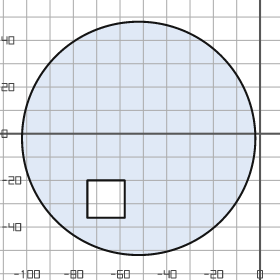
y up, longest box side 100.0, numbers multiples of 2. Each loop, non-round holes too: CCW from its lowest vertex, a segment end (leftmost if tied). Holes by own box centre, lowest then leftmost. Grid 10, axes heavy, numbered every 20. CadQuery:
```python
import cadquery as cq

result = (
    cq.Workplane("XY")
    .moveTo(-52.0, -2.0)
    .circle(50.0)
    .moveTo(-74.0, -36.0)
    .lineTo(-58.0, -36.0)
    .lineTo(-58.0, -20.0)
    .lineTo(-74.0, -20.0)
    .close()
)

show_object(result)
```